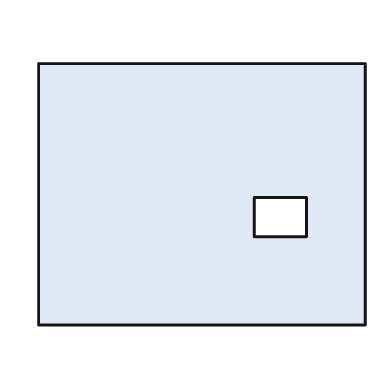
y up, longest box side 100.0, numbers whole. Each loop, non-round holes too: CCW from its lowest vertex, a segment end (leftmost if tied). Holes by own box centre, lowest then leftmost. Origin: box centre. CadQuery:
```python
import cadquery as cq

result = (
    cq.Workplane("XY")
    .moveTo(-50.0, -40.0)
    .lineTo(50.0, -40.0)
    .lineTo(50.0, 40.0)
    .lineTo(-50.0, 40.0)
    .close()
    .moveTo(16.0, -13.0)
    .lineTo(32.0, -13.0)
    .lineTo(32.0, -1.0)
    .lineTo(16.0, -1.0)
    .close()
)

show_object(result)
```